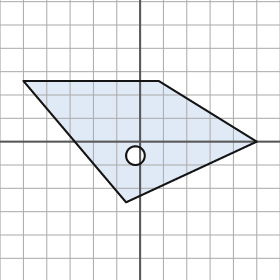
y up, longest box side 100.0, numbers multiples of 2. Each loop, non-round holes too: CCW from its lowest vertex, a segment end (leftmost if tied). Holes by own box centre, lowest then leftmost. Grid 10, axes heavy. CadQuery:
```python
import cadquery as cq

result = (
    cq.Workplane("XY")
    .moveTo(-6.0, -26.0)
    .lineTo(50.0, 0.0)
    .lineTo(8.0, 26.0)
    .lineTo(-50.0, 26.0)
    .close()
    .moveTo(-2.0, -6.0)
    .circle(4.0)
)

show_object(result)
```